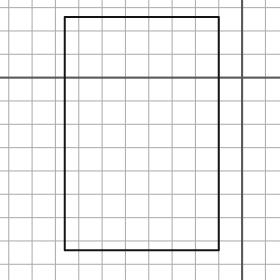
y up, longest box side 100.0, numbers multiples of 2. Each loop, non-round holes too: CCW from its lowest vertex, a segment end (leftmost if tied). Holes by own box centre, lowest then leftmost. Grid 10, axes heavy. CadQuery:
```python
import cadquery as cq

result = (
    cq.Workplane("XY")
    .moveTo(-76.0, -74.0)
    .lineTo(-10.0, -74.0)
    .lineTo(-10.0, 26.0)
    .lineTo(-76.0, 26.0)
    .close()
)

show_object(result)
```